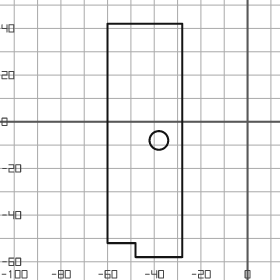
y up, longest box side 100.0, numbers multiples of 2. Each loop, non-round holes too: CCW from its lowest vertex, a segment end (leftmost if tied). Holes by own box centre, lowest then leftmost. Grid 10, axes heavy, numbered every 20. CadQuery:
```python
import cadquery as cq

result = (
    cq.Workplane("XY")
    .moveTo(-48.0, -58.0)
    .lineTo(-28.0, -58.0)
    .lineTo(-28.0, 42.0)
    .lineTo(-60.0, 42.0)
    .lineTo(-60.0, -52.0)
    .lineTo(-48.0, -52.0)
    .close()
    .moveTo(-38.0, -8.0)
    .circle(4.0)
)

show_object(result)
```